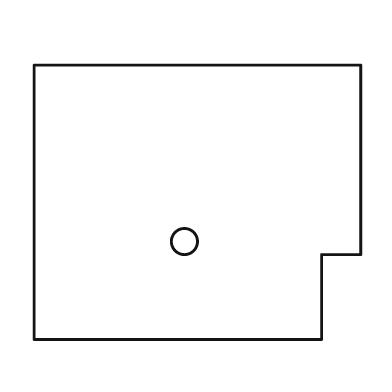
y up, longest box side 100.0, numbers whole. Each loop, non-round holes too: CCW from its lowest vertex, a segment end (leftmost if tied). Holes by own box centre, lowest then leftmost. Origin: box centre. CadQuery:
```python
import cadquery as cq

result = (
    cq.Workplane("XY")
    .moveTo(-50.0, -42.0)
    .lineTo(38.0, -42.0)
    .lineTo(38.0, -16.0)
    .lineTo(50.0, -16.0)
    .lineTo(50.0, 42.0)
    .lineTo(-50.0, 42.0)
    .close()
    .moveTo(-4.0, -12.0)
    .circle(4.0)
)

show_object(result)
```